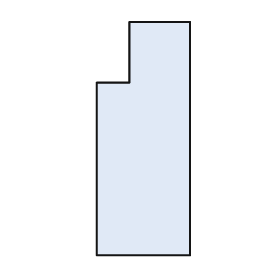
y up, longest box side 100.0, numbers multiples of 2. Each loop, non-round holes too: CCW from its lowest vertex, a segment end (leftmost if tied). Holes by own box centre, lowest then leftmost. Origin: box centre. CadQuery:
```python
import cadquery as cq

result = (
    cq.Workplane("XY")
    .moveTo(-20.0, -50.0)
    .lineTo(20.0, -50.0)
    .lineTo(20.0, 50.0)
    .lineTo(-6.0, 50.0)
    .lineTo(-6.0, 24.0)
    .lineTo(-20.0, 24.0)
    .close()
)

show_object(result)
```